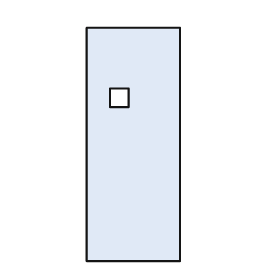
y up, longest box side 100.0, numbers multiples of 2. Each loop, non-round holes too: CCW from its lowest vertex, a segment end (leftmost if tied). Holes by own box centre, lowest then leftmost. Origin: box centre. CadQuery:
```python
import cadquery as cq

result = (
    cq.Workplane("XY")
    .moveTo(-20.0, -50.0)
    .lineTo(20.0, -50.0)
    .lineTo(20.0, 50.0)
    .lineTo(-20.0, 50.0)
    .close()
    .moveTo(-10.0, 16.0)
    .lineTo(-2.0, 16.0)
    .lineTo(-2.0, 24.0)
    .lineTo(-10.0, 24.0)
    .close()
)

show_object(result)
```